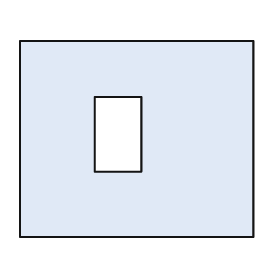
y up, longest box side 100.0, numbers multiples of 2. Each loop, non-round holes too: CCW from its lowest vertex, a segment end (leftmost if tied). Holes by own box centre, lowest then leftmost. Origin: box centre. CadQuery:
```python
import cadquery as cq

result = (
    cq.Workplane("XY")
    .moveTo(-50.0, -42.0)
    .lineTo(50.0, -42.0)
    .lineTo(50.0, 42.0)
    .lineTo(-50.0, 42.0)
    .close()
    .moveTo(-18.0, -14.0)
    .lineTo(2.0, -14.0)
    .lineTo(2.0, 18.0)
    .lineTo(-18.0, 18.0)
    .close()
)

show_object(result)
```